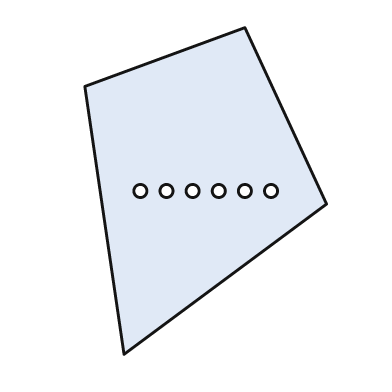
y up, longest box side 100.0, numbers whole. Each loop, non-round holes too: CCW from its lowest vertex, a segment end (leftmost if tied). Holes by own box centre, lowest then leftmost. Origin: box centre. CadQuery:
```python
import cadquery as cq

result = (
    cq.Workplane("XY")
    .moveTo(-25.0, -50.0)
    .lineTo(37.0, -4.0)
    .lineTo(12.0, 50.0)
    .lineTo(-37.0, 32.0)
    .close()
    .moveTo(-20.0, 0.0)
    .circle(2.0)
    .moveTo(-12.0, 0.0)
    .circle(2.0)
    .moveTo(-4.0, 0.0)
    .circle(2.0)
    .moveTo(4.0, 0.0)
    .circle(2.0)
    .moveTo(12.0, 0.0)
    .circle(2.0)
    .moveTo(20.0, 0.0)
    .circle(2.0)
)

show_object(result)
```